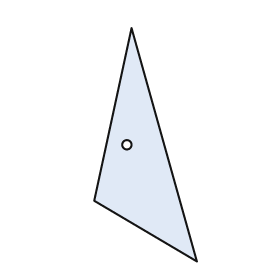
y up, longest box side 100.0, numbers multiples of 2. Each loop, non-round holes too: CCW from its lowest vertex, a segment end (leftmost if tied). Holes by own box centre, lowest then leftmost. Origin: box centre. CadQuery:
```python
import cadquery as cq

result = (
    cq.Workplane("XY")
    .moveTo(22.0, -50.0)
    .lineTo(-6.0, 50.0)
    .lineTo(-22.0, -24.0)
    .close()
    .moveTo(-8.0, 0.0)
    .circle(2.0)
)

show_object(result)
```